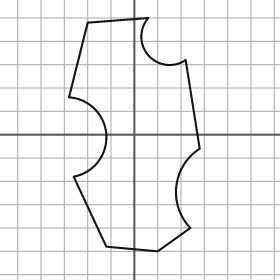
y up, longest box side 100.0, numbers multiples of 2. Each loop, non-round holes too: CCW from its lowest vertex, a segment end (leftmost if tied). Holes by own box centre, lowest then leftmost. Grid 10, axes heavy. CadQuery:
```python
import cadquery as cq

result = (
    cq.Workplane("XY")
    .moveTo(10.0, -50.0)
    .lineTo(24.0, -40.0)
    .threePointArc((18.0, -22.0), (28.0, -6.0))
    .lineTo(22.0, 32.0)
    .threePointArc((6.0, 34.0), (6.0, 50.0))
    .lineTo(-20.0, 48.0)
    .lineTo(-28.0, 16.0)
    .threePointArc((-12.0, 0.0), (-26.0, -18.0))
    .lineTo(-12.0, -48.0)
    .close()
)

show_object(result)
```